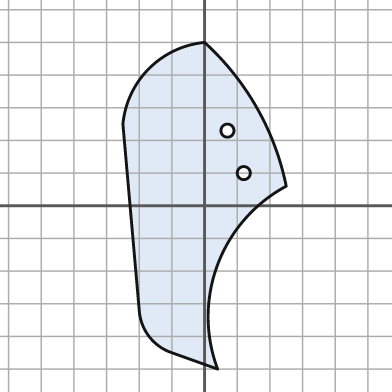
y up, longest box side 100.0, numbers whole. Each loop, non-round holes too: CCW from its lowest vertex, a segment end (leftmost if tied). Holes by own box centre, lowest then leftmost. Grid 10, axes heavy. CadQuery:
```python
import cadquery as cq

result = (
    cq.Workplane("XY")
    .moveTo(4.0, -50.0)
    .threePointArc((4.0, -18.0), (25.0, 6.0))
    .threePointArc((16.0, 30.0), (0.0, 50.0))
    .threePointArc((-17.0, 42.0), (-25.0, 25.0))
    .lineTo(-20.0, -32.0)
    .threePointArc((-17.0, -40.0), (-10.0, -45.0))
    .close()
    .moveTo(12.0, 10.0)
    .circle(2.0)
    .moveTo(7.0, 23.0)
    .circle(2.0)
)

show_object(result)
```